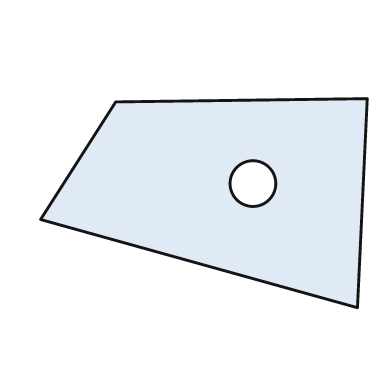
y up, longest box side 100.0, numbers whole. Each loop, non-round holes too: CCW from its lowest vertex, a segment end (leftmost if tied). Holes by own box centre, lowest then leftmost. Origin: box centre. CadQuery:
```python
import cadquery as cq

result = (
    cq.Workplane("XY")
    .moveTo(47.0, -32.0)
    .lineTo(50.0, 32.0)
    .lineTo(-27.0, 31.0)
    .lineTo(-50.0, -5.0)
    .close()
    .moveTo(15.0, 6.0)
    .circle(7.0)
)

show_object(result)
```